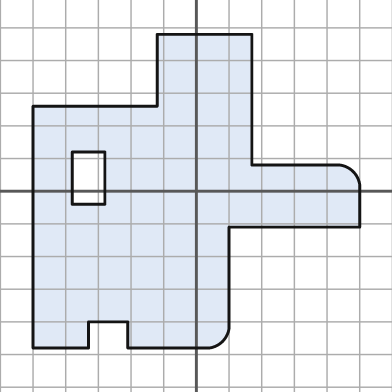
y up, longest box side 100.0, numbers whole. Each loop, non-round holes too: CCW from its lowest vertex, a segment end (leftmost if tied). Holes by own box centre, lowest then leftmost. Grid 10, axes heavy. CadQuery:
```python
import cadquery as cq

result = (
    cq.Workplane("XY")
    .moveTo(-50.0, -48.0)
    .lineTo(-33.0, -48.0)
    .lineTo(-33.0, -40.0)
    .lineTo(-21.0, -40.0)
    .lineTo(-21.0, -48.0)
    .lineTo(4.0, -48.0)
    .threePointArc((8.0, -46.0), (10.0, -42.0))
    .lineTo(10.0, -11.0)
    .lineTo(50.0, -11.0)
    .lineTo(50.0, 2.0)
    .threePointArc((48.0, 6.0), (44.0, 8.0))
    .lineTo(17.0, 8.0)
    .lineTo(17.0, 48.0)
    .lineTo(-12.0, 48.0)
    .lineTo(-12.0, 26.0)
    .lineTo(-50.0, 26.0)
    .close()
    .moveTo(-38.0, -4.0)
    .lineTo(-28.0, -4.0)
    .lineTo(-28.0, 12.0)
    .lineTo(-38.0, 12.0)
    .close()
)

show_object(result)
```